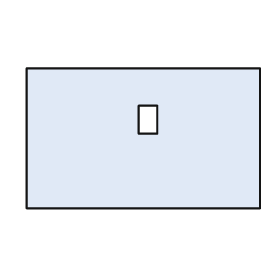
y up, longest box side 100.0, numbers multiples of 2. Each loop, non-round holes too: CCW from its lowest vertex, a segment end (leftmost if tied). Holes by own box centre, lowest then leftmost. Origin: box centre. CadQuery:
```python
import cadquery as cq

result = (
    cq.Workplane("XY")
    .moveTo(-50.0, -30.0)
    .lineTo(50.0, -30.0)
    .lineTo(50.0, 30.0)
    .lineTo(-50.0, 30.0)
    .close()
    .moveTo(-2.0, 2.0)
    .lineTo(6.0, 2.0)
    .lineTo(6.0, 14.0)
    .lineTo(-2.0, 14.0)
    .close()
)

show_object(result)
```